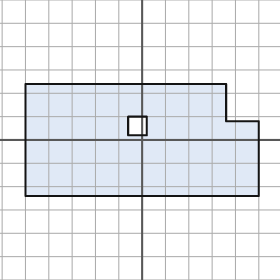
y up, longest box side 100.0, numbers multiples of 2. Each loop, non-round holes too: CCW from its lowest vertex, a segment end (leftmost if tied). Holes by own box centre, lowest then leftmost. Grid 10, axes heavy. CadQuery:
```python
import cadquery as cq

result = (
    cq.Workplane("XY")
    .moveTo(-50.0, -24.0)
    .lineTo(50.0, -24.0)
    .lineTo(50.0, 8.0)
    .lineTo(36.0, 8.0)
    .lineTo(36.0, 24.0)
    .lineTo(-50.0, 24.0)
    .close()
    .moveTo(-6.0, 2.0)
    .lineTo(2.0, 2.0)
    .lineTo(2.0, 10.0)
    .lineTo(-6.0, 10.0)
    .close()
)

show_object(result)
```